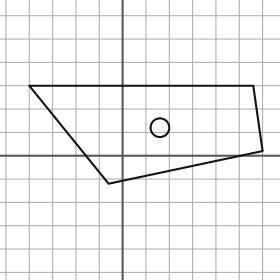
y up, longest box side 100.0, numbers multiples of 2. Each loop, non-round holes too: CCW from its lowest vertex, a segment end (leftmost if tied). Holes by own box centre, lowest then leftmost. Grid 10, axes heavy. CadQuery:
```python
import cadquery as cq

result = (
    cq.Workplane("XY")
    .moveTo(-6.0, -12.0)
    .lineTo(60.0, 2.0)
    .lineTo(56.0, 30.0)
    .lineTo(-40.0, 30.0)
    .close()
    .moveTo(16.0, 12.0)
    .circle(4.0)
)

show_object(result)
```